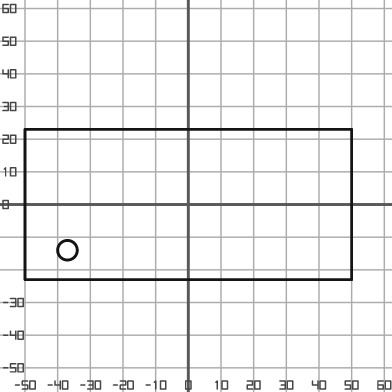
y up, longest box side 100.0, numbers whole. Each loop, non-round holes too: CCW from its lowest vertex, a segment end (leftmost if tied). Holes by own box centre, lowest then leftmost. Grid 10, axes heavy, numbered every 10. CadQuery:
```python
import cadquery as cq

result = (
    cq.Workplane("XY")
    .moveTo(-50.0, -23.0)
    .lineTo(50.0, -23.0)
    .lineTo(50.0, 23.0)
    .lineTo(-50.0, 23.0)
    .close()
    .moveTo(-37.0, -14.0)
    .circle(3.0)
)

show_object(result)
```